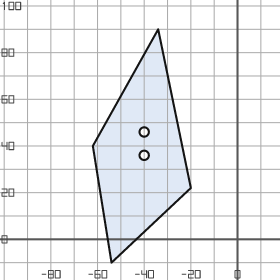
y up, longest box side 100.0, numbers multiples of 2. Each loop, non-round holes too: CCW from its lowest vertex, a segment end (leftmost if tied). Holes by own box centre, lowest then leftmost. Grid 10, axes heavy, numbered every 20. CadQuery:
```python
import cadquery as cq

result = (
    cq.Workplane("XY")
    .moveTo(-54.0, -10.0)
    .lineTo(-20.0, 22.0)
    .lineTo(-34.0, 90.0)
    .lineTo(-62.0, 40.0)
    .close()
    .moveTo(-40.0, 36.0)
    .circle(2.0)
    .moveTo(-40.0, 46.0)
    .circle(2.0)
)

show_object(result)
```